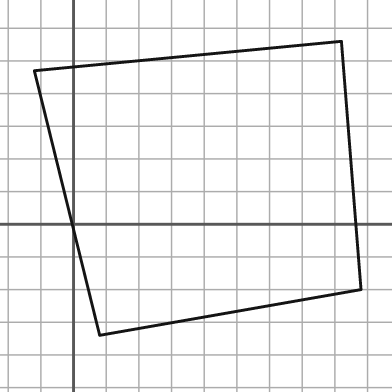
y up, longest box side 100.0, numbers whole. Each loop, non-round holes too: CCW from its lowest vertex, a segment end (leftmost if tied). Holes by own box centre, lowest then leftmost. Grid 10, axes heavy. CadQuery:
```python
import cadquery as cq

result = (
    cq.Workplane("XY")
    .moveTo(8.0, -34.0)
    .lineTo(88.0, -20.0)
    .lineTo(82.0, 56.0)
    .lineTo(-12.0, 47.0)
    .close()
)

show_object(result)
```